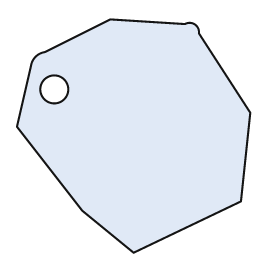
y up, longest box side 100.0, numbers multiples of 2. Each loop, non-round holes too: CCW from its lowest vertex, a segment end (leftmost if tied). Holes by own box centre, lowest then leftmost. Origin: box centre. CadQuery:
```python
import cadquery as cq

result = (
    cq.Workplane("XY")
    .moveTo(0.0, -50.0)
    .lineTo(46.0, -28.0)
    .lineTo(50.0, 10.0)
    .lineTo(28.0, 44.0)
    .threePointArc((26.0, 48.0), (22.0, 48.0))
    .lineTo(-10.0, 50.0)
    .lineTo(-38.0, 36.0)
    .threePointArc((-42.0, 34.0), (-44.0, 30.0))
    .lineTo(-50.0, 4.0)
    .lineTo(-22.0, -32.0)
    .close()
    .moveTo(-34.0, 20.0)
    .circle(6.0)
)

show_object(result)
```